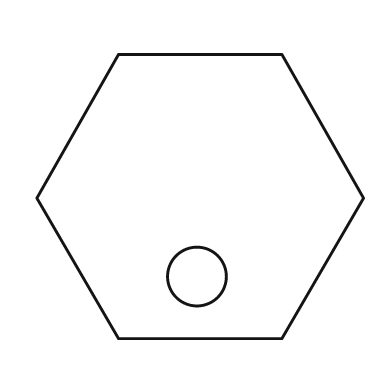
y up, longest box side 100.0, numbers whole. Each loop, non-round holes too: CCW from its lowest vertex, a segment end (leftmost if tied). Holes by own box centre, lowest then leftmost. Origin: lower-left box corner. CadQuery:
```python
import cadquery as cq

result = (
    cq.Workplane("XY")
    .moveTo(25.0, 0.0)
    .lineTo(75.0, 0.0)
    .lineTo(100.0, 43.0)
    .lineTo(75.0, 87.0)
    .lineTo(25.0, 87.0)
    .lineTo(0.0, 43.0)
    .close()
    .moveTo(49.0, 19.0)
    .circle(9.0)
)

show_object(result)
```